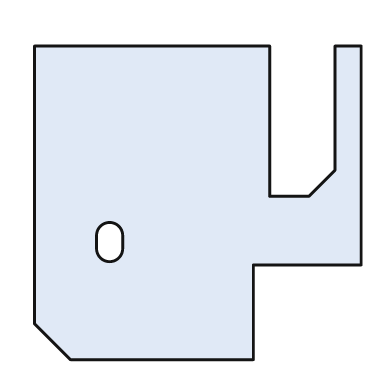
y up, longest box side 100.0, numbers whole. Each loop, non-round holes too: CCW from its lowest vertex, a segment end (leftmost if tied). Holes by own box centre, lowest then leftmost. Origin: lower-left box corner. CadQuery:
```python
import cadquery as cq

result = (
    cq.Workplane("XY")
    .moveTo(11.0, 0.0)
    .lineTo(67.0, 0.0)
    .lineTo(67.0, 29.0)
    .lineTo(100.0, 29.0)
    .lineTo(100.0, 96.0)
    .lineTo(92.0, 96.0)
    .lineTo(92.0, 58.0)
    .lineTo(84.0, 50.0)
    .lineTo(72.0, 50.0)
    .lineTo(72.0, 96.0)
    .lineTo(0.0, 96.0)
    .lineTo(0.0, 11.0)
    .close()
    .moveTo(19.0, 34.0)
    .threePointArc((23.0, 30.0), (27.0, 34.0))
    .lineTo(27.0, 38.0)
    .threePointArc((23.0, 42.0), (19.0, 38.0))
    .close()
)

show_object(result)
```